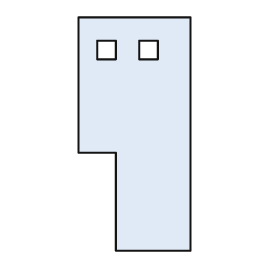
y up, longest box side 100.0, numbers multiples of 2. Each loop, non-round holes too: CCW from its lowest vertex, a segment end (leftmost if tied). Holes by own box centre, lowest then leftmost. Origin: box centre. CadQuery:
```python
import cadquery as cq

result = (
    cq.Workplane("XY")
    .moveTo(-8.0, -50.0)
    .lineTo(24.0, -50.0)
    .lineTo(24.0, 50.0)
    .lineTo(-24.0, 50.0)
    .lineTo(-24.0, -8.0)
    .lineTo(-8.0, -8.0)
    .close()
    .moveTo(-16.0, 32.0)
    .lineTo(-8.0, 32.0)
    .lineTo(-8.0, 40.0)
    .lineTo(-16.0, 40.0)
    .close()
    .moveTo(2.0, 32.0)
    .lineTo(10.0, 32.0)
    .lineTo(10.0, 40.0)
    .lineTo(2.0, 40.0)
    .close()
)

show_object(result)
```